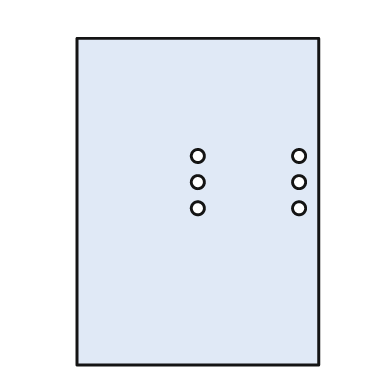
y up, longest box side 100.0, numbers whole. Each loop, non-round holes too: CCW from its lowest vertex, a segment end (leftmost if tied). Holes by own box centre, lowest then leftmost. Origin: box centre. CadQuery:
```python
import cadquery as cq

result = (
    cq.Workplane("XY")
    .moveTo(-37.0, -50.0)
    .lineTo(37.0, -50.0)
    .lineTo(37.0, 50.0)
    .lineTo(-37.0, 50.0)
    .close()
    .moveTo(0.0, -2.0)
    .circle(2.0)
    .moveTo(31.0, -2.0)
    .circle(2.0)
    .moveTo(0.0, 6.0)
    .circle(2.0)
    .moveTo(31.0, 6.0)
    .circle(2.0)
    .moveTo(0.0, 14.0)
    .circle(2.0)
    .moveTo(31.0, 14.0)
    .circle(2.0)
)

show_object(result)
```